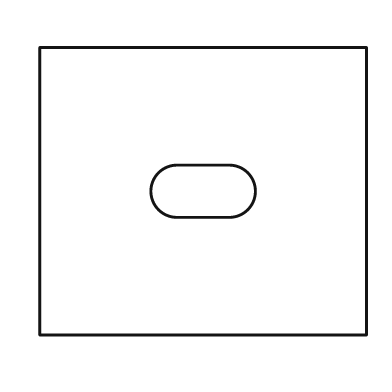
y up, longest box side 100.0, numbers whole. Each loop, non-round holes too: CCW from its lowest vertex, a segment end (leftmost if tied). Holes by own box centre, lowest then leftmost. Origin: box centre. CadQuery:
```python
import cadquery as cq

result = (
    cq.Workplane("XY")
    .moveTo(-50.0, -44.0)
    .lineTo(50.0, -44.0)
    .lineTo(50.0, 44.0)
    .lineTo(-50.0, 44.0)
    .close()
    .moveTo(-8.0, -8.0)
    .lineTo(8.0, -8.0)
    .threePointArc((16.0, 0.0), (8.0, 8.0))
    .lineTo(-8.0, 8.0)
    .threePointArc((-16.0, 0.0), (-8.0, -8.0))
    .close()
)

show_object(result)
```